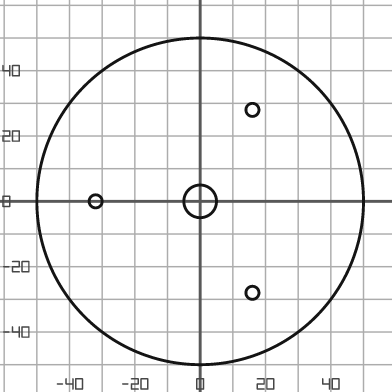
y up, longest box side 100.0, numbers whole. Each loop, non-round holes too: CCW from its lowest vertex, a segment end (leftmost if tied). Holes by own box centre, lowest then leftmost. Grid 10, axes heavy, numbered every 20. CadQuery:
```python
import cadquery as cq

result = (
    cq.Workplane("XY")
    .moveTo(0.0, 0.0)
    .circle(50.0)
    .moveTo(16.0, -28.0)
    .circle(2.0)
    .moveTo(-32.0, 0.0)
    .circle(2.0)
    .moveTo(0.0, 0.0)
    .circle(5.0)
    .moveTo(16.0, 28.0)
    .circle(2.0)
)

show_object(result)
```